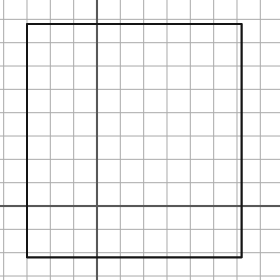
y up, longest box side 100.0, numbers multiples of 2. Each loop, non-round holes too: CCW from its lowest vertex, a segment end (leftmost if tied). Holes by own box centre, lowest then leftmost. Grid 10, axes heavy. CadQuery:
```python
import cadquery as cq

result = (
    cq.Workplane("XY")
    .moveTo(-30.0, -22.0)
    .lineTo(62.0, -22.0)
    .lineTo(62.0, 78.0)
    .lineTo(-30.0, 78.0)
    .close()
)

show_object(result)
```